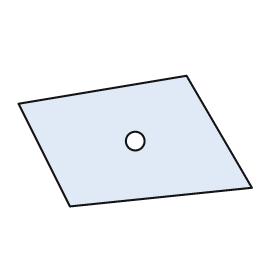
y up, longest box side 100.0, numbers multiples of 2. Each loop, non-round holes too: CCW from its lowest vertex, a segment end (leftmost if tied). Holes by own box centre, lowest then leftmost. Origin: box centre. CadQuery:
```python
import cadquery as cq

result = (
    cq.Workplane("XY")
    .moveTo(-28.0, -28.0)
    .lineTo(50.0, -20.0)
    .lineTo(22.0, 28.0)
    .lineTo(-50.0, 16.0)
    .close()
    .moveTo(0.0, 0.0)
    .circle(4.0)
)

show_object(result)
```